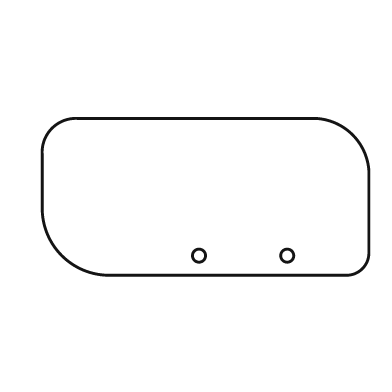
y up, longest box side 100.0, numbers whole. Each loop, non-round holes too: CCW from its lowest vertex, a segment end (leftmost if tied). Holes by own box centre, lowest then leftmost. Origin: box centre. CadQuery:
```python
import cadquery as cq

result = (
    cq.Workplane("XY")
    .moveTo(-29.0, -24.0)
    .lineTo(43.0, -24.0)
    .threePointArc((48.0, -22.0), (50.0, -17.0))
    .lineTo(50.0, 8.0)
    .threePointArc((45.0, 19.0), (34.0, 24.0))
    .lineTo(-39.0, 24.0)
    .threePointArc((-47.0, 21.0), (-50.0, 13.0))
    .lineTo(-50.0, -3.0)
    .threePointArc((-44.0, -18.0), (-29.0, -24.0))
    .close()
    .moveTo(-2.0, -18.0)
    .circle(2.0)
    .moveTo(25.0, -18.0)
    .circle(2.0)
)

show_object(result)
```